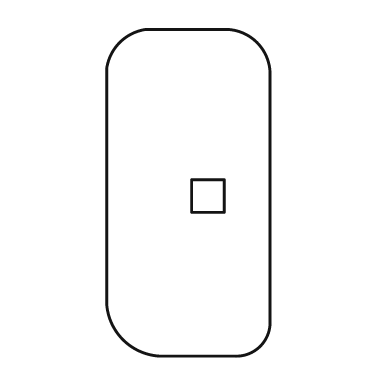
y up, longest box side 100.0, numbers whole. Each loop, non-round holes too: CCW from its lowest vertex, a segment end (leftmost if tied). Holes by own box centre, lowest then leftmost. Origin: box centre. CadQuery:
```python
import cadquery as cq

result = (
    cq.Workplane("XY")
    .moveTo(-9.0, -50.0)
    .lineTo(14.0, -50.0)
    .threePointArc((22.0, -47.0), (25.0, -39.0))
    .lineTo(25.0, 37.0)
    .threePointArc((21.0, 46.0), (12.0, 50.0))
    .lineTo(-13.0, 50.0)
    .threePointArc((-21.0, 46.0), (-25.0, 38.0))
    .lineTo(-25.0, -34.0)
    .threePointArc((-20.0, -45.0), (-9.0, -50.0))
    .close()
    .moveTo(1.0, -6.0)
    .lineTo(11.0, -6.0)
    .lineTo(11.0, 4.0)
    .lineTo(1.0, 4.0)
    .close()
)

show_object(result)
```